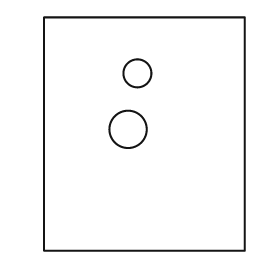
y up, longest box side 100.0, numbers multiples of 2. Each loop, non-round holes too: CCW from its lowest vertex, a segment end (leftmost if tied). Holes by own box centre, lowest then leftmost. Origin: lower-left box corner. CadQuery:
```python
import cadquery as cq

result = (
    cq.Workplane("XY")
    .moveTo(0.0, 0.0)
    .lineTo(86.0, 0.0)
    .lineTo(86.0, 100.0)
    .lineTo(0.0, 100.0)
    .close()
    .moveTo(36.0, 52.0)
    .circle(8.0)
    .moveTo(40.0, 76.0)
    .circle(6.0)
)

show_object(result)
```